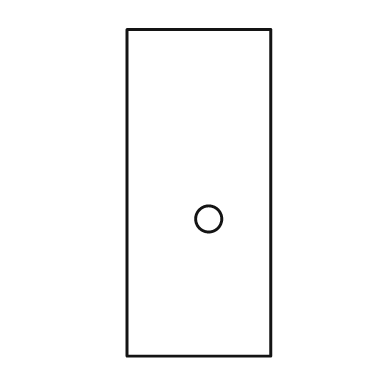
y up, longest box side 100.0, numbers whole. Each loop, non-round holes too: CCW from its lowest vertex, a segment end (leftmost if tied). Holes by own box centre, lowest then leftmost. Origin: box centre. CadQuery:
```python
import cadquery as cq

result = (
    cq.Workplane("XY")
    .moveTo(-22.0, -50.0)
    .lineTo(22.0, -50.0)
    .lineTo(22.0, 50.0)
    .lineTo(-22.0, 50.0)
    .close()
    .moveTo(3.0, -8.0)
    .circle(4.0)
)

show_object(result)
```